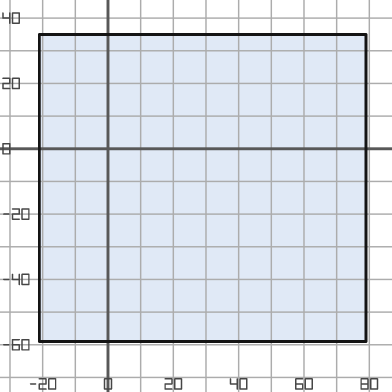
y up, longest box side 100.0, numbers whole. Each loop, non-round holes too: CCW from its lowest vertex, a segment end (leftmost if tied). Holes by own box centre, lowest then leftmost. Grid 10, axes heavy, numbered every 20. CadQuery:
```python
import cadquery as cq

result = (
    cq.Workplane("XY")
    .moveTo(-21.0, -59.0)
    .lineTo(79.0, -59.0)
    .lineTo(79.0, 35.0)
    .lineTo(-21.0, 35.0)
    .close()
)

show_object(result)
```